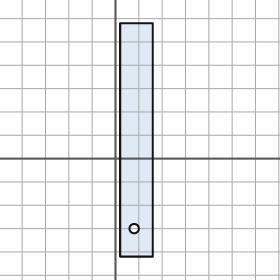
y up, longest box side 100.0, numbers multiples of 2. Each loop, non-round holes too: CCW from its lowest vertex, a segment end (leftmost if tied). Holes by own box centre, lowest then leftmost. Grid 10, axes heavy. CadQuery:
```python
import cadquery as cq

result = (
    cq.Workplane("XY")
    .moveTo(2.0, -42.0)
    .lineTo(16.0, -42.0)
    .lineTo(16.0, 58.0)
    .lineTo(2.0, 58.0)
    .close()
    .moveTo(8.0, -30.0)
    .circle(2.0)
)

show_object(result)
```